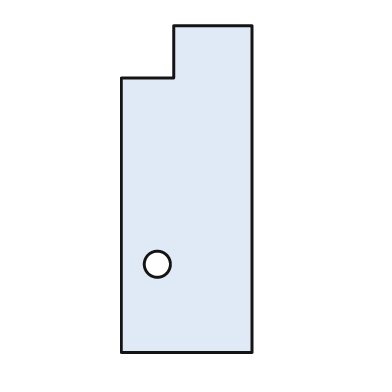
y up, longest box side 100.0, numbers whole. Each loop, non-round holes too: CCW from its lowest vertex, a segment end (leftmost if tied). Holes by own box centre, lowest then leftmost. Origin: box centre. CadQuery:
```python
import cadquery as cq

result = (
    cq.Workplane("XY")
    .moveTo(-20.0, -50.0)
    .lineTo(20.0, -50.0)
    .lineTo(20.0, 50.0)
    .lineTo(-4.0, 50.0)
    .lineTo(-4.0, 34.0)
    .lineTo(-20.0, 34.0)
    .close()
    .moveTo(-9.0, -23.0)
    .circle(4.0)
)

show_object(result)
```